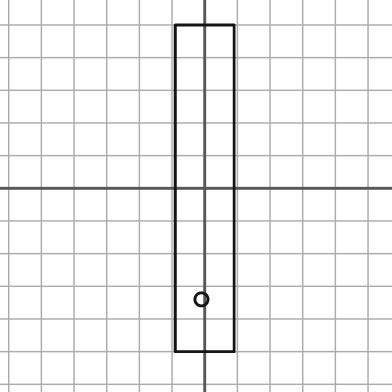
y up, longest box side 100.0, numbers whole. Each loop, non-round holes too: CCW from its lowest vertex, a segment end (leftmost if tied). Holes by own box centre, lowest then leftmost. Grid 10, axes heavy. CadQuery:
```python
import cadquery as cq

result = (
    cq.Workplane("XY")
    .moveTo(-9.0, -50.0)
    .lineTo(9.0, -50.0)
    .lineTo(9.0, 50.0)
    .lineTo(-9.0, 50.0)
    .close()
    .moveTo(-1.0, -34.0)
    .circle(2.0)
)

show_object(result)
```